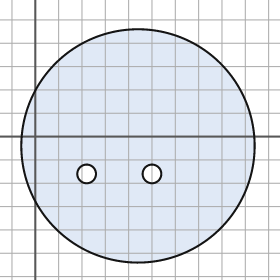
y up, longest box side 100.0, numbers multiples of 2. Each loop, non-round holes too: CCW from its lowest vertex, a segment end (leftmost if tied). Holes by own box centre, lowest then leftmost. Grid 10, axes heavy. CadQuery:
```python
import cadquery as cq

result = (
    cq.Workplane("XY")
    .moveTo(44.0, -4.0)
    .circle(50.0)
    .moveTo(22.0, -16.0)
    .circle(4.0)
    .moveTo(50.0, -16.0)
    .circle(4.0)
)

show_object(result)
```